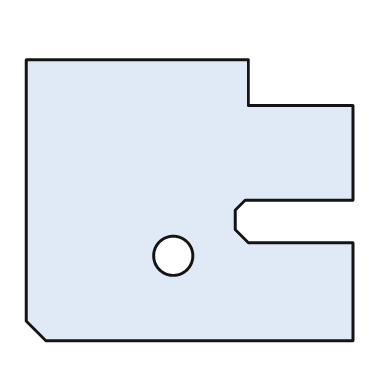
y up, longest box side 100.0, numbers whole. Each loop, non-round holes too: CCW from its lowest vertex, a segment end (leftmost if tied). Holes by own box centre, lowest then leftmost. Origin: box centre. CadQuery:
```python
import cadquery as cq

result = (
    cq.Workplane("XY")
    .moveTo(-44.0, -43.0)
    .lineTo(50.0, -43.0)
    .lineTo(50.0, -13.0)
    .lineTo(18.0, -13.0)
    .lineTo(14.0, -9.0)
    .lineTo(14.0, -3.0)
    .lineTo(17.0, 0.0)
    .lineTo(50.0, 0.0)
    .lineTo(50.0, 29.0)
    .lineTo(18.0, 29.0)
    .lineTo(18.0, 43.0)
    .lineTo(-50.0, 43.0)
    .lineTo(-50.0, -37.0)
    .close()
    .moveTo(-5.0, -17.0)
    .circle(6.0)
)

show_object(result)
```